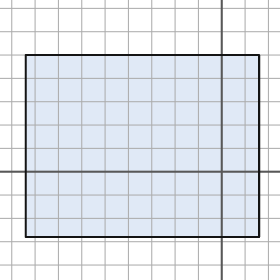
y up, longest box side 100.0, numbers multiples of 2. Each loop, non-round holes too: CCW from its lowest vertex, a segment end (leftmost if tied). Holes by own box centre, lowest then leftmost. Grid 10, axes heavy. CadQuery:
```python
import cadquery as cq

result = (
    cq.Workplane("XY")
    .moveTo(-84.0, -28.0)
    .lineTo(16.0, -28.0)
    .lineTo(16.0, 50.0)
    .lineTo(-84.0, 50.0)
    .close()
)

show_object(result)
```